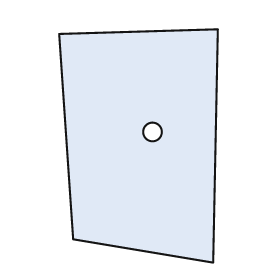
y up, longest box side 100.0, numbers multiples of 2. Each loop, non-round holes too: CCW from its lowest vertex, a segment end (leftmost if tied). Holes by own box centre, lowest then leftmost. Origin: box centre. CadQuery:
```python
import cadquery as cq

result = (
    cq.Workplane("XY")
    .moveTo(32.0, -50.0)
    .lineTo(34.0, 50.0)
    .lineTo(-34.0, 48.0)
    .lineTo(-28.0, -40.0)
    .close()
    .moveTo(6.0, 6.0)
    .circle(4.0)
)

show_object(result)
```